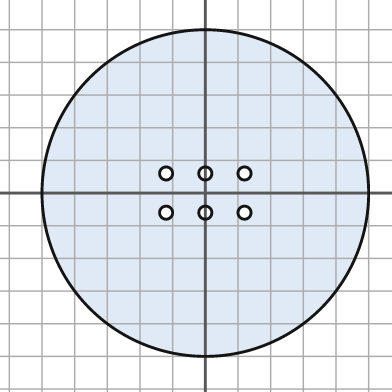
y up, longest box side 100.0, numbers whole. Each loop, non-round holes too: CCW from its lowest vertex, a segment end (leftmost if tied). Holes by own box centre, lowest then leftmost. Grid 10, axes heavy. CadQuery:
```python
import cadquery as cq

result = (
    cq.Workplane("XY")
    .moveTo(0.0, 0.0)
    .circle(50.0)
    .moveTo(-12.0, -6.0)
    .circle(2.0)
    .moveTo(0.0, -6.0)
    .circle(2.0)
    .moveTo(12.0, -6.0)
    .circle(2.0)
    .moveTo(-12.0, 6.0)
    .circle(2.0)
    .moveTo(0.0, 6.0)
    .circle(2.0)
    .moveTo(12.0, 6.0)
    .circle(2.0)
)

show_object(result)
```